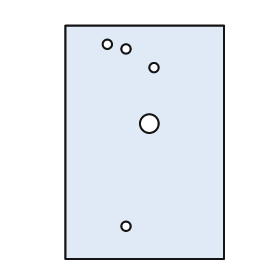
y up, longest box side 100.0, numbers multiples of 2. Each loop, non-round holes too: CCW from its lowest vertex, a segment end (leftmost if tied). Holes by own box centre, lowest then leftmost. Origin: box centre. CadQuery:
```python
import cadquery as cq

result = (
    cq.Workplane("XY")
    .moveTo(-34.0, -50.0)
    .lineTo(34.0, -50.0)
    .lineTo(34.0, 50.0)
    .lineTo(-34.0, 50.0)
    .close()
    .moveTo(-8.0, -36.0)
    .circle(2.0)
    .moveTo(2.0, 8.0)
    .circle(4.0)
    .moveTo(4.0, 32.0)
    .circle(2.0)
    .moveTo(-8.0, 40.0)
    .circle(2.0)
    .moveTo(-16.0, 42.0)
    .circle(2.0)
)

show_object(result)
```